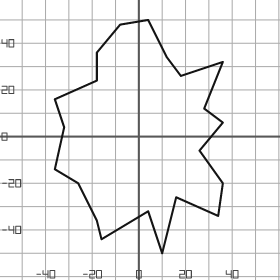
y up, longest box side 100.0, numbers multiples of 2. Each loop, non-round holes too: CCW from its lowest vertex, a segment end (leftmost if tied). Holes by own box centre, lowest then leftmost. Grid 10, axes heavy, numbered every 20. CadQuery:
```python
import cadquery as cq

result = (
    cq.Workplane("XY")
    .moveTo(10.0, -50.0)
    .lineTo(16.0, -26.0)
    .lineTo(34.0, -34.0)
    .lineTo(36.0, -20.0)
    .lineTo(26.0, -6.0)
    .lineTo(36.0, 6.0)
    .lineTo(28.0, 12.0)
    .lineTo(36.0, 32.0)
    .lineTo(18.0, 26.0)
    .lineTo(12.0, 34.0)
    .lineTo(4.0, 50.0)
    .lineTo(-8.0, 48.0)
    .lineTo(-18.0, 36.0)
    .lineTo(-18.0, 24.0)
    .lineTo(-36.0, 16.0)
    .lineTo(-32.0, 4.0)
    .lineTo(-36.0, -14.0)
    .lineTo(-26.0, -20.0)
    .lineTo(-18.0, -36.0)
    .lineTo(-16.0, -44.0)
    .lineTo(4.0, -32.0)
    .close()
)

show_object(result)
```